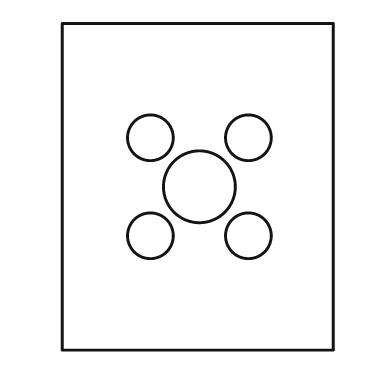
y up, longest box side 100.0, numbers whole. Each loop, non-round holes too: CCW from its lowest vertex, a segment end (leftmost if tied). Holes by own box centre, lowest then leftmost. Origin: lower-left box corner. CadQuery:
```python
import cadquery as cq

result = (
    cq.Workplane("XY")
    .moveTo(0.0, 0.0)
    .lineTo(83.0, 0.0)
    .lineTo(83.0, 100.0)
    .lineTo(0.0, 100.0)
    .close()
    .moveTo(27.0, 35.0)
    .circle(7.0)
    .moveTo(57.0, 35.0)
    .circle(7.0)
    .moveTo(42.0, 50.0)
    .circle(11.0)
    .moveTo(27.0, 65.0)
    .circle(7.0)
    .moveTo(57.0, 65.0)
    .circle(7.0)
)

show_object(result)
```